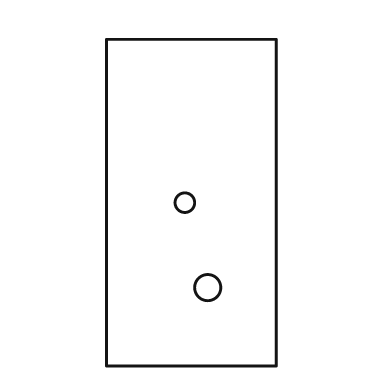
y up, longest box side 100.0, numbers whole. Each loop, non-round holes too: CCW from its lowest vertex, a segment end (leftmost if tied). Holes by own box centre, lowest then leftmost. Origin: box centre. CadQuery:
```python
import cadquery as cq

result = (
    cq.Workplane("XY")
    .moveTo(-26.0, -50.0)
    .lineTo(26.0, -50.0)
    .lineTo(26.0, 50.0)
    .lineTo(-26.0, 50.0)
    .close()
    .moveTo(5.0, -26.0)
    .circle(4.0)
    .moveTo(-2.0, 0.0)
    .circle(3.0)
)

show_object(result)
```